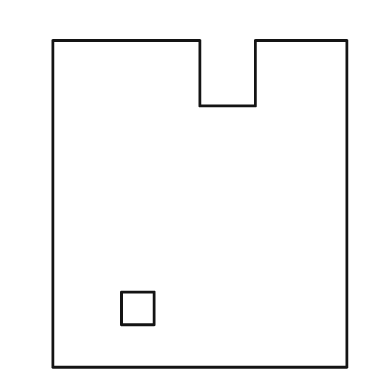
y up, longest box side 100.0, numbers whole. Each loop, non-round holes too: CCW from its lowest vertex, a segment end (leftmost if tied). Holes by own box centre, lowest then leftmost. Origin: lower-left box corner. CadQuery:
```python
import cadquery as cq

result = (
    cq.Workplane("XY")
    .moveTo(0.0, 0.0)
    .lineTo(90.0, 0.0)
    .lineTo(90.0, 100.0)
    .lineTo(62.0, 100.0)
    .lineTo(62.0, 80.0)
    .lineTo(45.0, 80.0)
    .lineTo(45.0, 100.0)
    .lineTo(0.0, 100.0)
    .close()
    .moveTo(21.0, 13.0)
    .lineTo(31.0, 13.0)
    .lineTo(31.0, 23.0)
    .lineTo(21.0, 23.0)
    .close()
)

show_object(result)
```